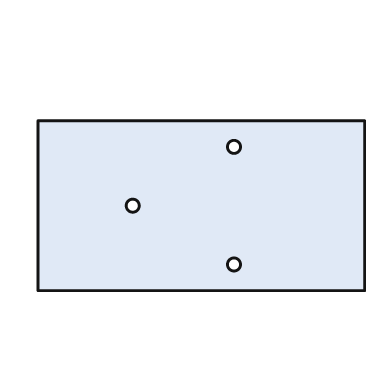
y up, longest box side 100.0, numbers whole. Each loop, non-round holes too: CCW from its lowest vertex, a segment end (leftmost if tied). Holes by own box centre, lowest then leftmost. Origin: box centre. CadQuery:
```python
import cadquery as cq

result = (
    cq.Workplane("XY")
    .moveTo(-50.0, -26.0)
    .lineTo(50.0, -26.0)
    .lineTo(50.0, 26.0)
    .lineTo(-50.0, 26.0)
    .close()
    .moveTo(10.0, -18.0)
    .circle(2.0)
    .moveTo(-21.0, 0.0)
    .circle(2.0)
    .moveTo(10.0, 18.0)
    .circle(2.0)
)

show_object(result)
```